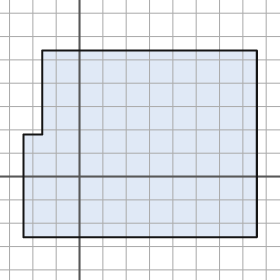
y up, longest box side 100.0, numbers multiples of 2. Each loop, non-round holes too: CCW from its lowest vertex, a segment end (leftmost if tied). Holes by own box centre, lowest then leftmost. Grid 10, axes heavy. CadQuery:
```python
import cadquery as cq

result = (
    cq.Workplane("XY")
    .moveTo(-24.0, -26.0)
    .lineTo(76.0, -26.0)
    .lineTo(76.0, 54.0)
    .lineTo(-16.0, 54.0)
    .lineTo(-16.0, 18.0)
    .lineTo(-24.0, 18.0)
    .close()
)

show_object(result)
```